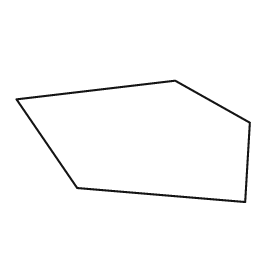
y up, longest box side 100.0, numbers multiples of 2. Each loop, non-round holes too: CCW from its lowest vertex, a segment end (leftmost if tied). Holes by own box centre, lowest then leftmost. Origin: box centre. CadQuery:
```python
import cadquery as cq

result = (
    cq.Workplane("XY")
    .moveTo(48.0, -26.0)
    .lineTo(50.0, 8.0)
    .lineTo(18.0, 26.0)
    .lineTo(-50.0, 18.0)
    .lineTo(-24.0, -20.0)
    .close()
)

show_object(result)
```